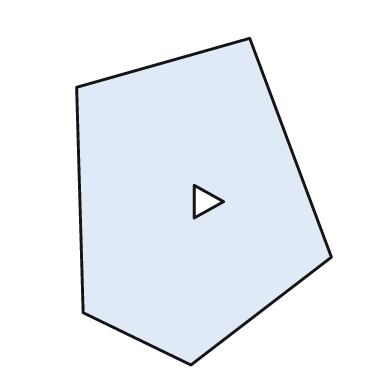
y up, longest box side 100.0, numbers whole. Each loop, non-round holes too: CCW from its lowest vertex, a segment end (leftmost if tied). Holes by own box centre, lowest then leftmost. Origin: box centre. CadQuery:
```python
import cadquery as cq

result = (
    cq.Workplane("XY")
    .moveTo(-4.0, -50.0)
    .lineTo(39.0, -17.0)
    .lineTo(14.0, 50.0)
    .lineTo(-39.0, 35.0)
    .lineTo(-37.0, -34.0)
    .close()
    .moveTo(-3.0, -5.0)
    .lineTo(6.0, 0.0)
    .lineTo(-3.0, 5.0)
    .close()
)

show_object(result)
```